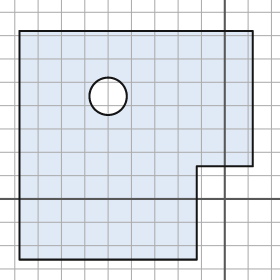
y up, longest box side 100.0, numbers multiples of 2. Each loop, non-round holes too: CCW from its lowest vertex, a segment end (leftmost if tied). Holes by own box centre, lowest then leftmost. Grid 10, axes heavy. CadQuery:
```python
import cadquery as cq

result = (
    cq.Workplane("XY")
    .moveTo(-88.0, -26.0)
    .lineTo(-12.0, -26.0)
    .lineTo(-12.0, 14.0)
    .lineTo(12.0, 14.0)
    .lineTo(12.0, 72.0)
    .lineTo(-88.0, 72.0)
    .close()
    .moveTo(-50.0, 44.0)
    .circle(8.0)
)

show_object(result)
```